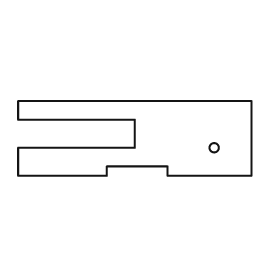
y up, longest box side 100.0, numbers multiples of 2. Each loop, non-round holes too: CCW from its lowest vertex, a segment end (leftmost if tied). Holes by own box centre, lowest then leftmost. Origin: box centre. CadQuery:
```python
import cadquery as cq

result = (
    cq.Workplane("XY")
    .moveTo(-50.0, -16.0)
    .lineTo(-12.0, -16.0)
    .lineTo(-12.0, -12.0)
    .lineTo(14.0, -12.0)
    .lineTo(14.0, -16.0)
    .lineTo(50.0, -16.0)
    .lineTo(50.0, 16.0)
    .lineTo(-50.0, 16.0)
    .lineTo(-50.0, 8.0)
    .lineTo(0.0, 8.0)
    .lineTo(0.0, -4.0)
    .lineTo(-50.0, -4.0)
    .close()
    .moveTo(34.0, -4.0)
    .circle(2.0)
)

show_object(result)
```